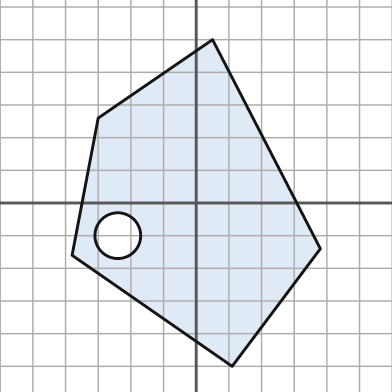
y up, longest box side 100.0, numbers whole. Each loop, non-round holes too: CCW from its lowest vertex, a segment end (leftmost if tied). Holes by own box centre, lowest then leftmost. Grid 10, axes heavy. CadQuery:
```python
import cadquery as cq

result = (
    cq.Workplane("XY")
    .moveTo(11.0, -50.0)
    .lineTo(38.0, -14.0)
    .lineTo(5.0, 50.0)
    .lineTo(-30.0, 26.0)
    .lineTo(-38.0, -16.0)
    .close()
    .moveTo(-24.0, -10.0)
    .circle(7.0)
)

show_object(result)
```